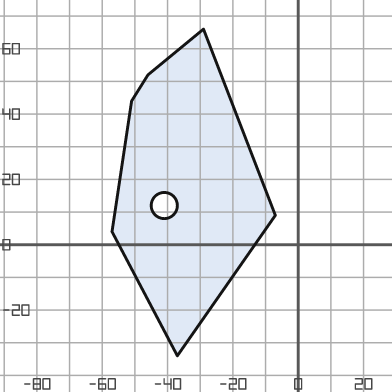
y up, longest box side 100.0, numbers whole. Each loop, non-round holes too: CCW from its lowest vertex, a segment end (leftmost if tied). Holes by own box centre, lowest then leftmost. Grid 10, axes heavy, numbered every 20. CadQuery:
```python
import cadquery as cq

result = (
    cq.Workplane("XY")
    .moveTo(-37.0, -34.0)
    .lineTo(-7.0, 9.0)
    .lineTo(-29.0, 66.0)
    .lineTo(-46.0, 52.0)
    .lineTo(-51.0, 44.0)
    .lineTo(-57.0, 4.0)
    .close()
    .moveTo(-41.0, 12.0)
    .circle(4.0)
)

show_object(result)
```